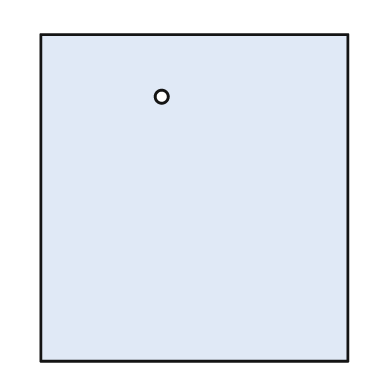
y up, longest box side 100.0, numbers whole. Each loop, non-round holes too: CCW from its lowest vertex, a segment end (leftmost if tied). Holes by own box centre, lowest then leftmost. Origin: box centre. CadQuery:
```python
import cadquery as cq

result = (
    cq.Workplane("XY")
    .moveTo(-47.0, -50.0)
    .lineTo(47.0, -50.0)
    .lineTo(47.0, 50.0)
    .lineTo(-47.0, 50.0)
    .close()
    .moveTo(-10.0, 31.0)
    .circle(2.0)
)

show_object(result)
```